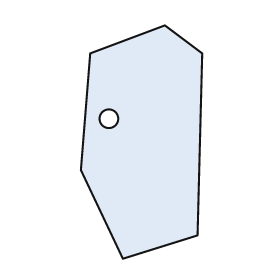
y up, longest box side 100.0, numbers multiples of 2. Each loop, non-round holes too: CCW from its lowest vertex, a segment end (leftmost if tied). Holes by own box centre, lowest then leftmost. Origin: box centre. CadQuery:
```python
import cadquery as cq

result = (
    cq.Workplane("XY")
    .moveTo(-8.0, -50.0)
    .lineTo(24.0, -40.0)
    .lineTo(26.0, 38.0)
    .lineTo(10.0, 50.0)
    .lineTo(-22.0, 38.0)
    .lineTo(-26.0, -12.0)
    .close()
    .moveTo(-14.0, 10.0)
    .circle(4.0)
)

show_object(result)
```